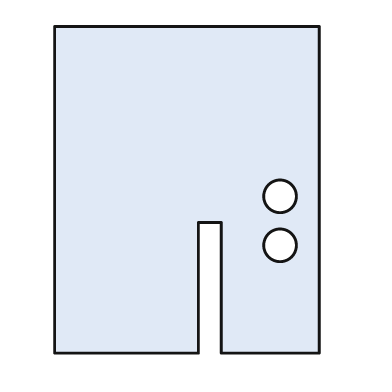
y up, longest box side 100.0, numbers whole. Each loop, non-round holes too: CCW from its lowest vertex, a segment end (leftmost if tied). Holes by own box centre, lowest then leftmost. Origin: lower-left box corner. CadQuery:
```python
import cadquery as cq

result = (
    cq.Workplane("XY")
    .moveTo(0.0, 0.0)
    .lineTo(44.0, 0.0)
    .lineTo(44.0, 40.0)
    .lineTo(51.0, 40.0)
    .lineTo(51.0, 0.0)
    .lineTo(81.0, 0.0)
    .lineTo(81.0, 100.0)
    .lineTo(0.0, 100.0)
    .close()
    .moveTo(69.0, 33.0)
    .circle(5.0)
    .moveTo(69.0, 48.0)
    .circle(5.0)
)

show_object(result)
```